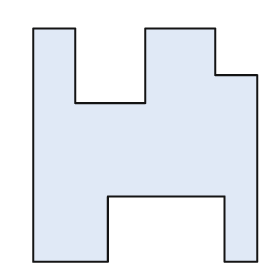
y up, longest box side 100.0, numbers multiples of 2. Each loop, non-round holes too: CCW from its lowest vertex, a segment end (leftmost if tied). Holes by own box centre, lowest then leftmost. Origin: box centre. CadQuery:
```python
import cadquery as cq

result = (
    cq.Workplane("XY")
    .moveTo(-48.0, -50.0)
    .lineTo(-16.0, -50.0)
    .lineTo(-16.0, -22.0)
    .lineTo(34.0, -22.0)
    .lineTo(34.0, -50.0)
    .lineTo(48.0, -50.0)
    .lineTo(48.0, 30.0)
    .lineTo(30.0, 30.0)
    .lineTo(30.0, 50.0)
    .lineTo(0.0, 50.0)
    .lineTo(0.0, 18.0)
    .lineTo(-30.0, 18.0)
    .lineTo(-30.0, 50.0)
    .lineTo(-48.0, 50.0)
    .close()
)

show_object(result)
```